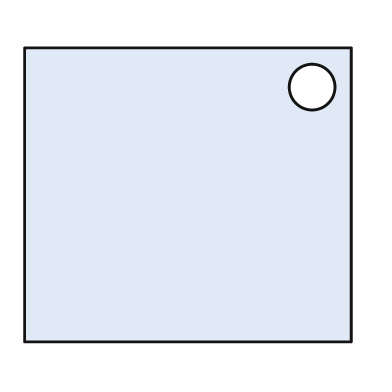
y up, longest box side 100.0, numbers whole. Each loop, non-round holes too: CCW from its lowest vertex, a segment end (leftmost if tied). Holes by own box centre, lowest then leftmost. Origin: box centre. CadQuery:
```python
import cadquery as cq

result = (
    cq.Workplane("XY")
    .moveTo(-50.0, -45.0)
    .lineTo(50.0, -45.0)
    .lineTo(50.0, 45.0)
    .lineTo(-50.0, 45.0)
    .close()
    .moveTo(38.0, 33.0)
    .circle(7.0)
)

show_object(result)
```